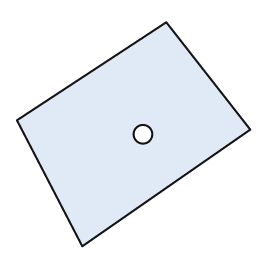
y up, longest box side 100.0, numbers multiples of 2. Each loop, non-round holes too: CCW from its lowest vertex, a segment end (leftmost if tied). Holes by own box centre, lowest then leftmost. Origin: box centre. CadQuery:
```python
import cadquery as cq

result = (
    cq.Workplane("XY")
    .moveTo(-22.0, -48.0)
    .lineTo(50.0, 2.0)
    .lineTo(14.0, 48.0)
    .lineTo(-50.0, 6.0)
    .close()
    .moveTo(4.0, 0.0)
    .circle(4.0)
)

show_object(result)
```